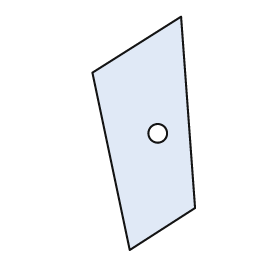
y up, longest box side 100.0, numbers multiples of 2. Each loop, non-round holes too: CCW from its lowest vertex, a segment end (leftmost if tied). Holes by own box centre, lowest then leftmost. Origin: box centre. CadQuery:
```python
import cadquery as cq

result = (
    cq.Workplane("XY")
    .moveTo(-6.0, -50.0)
    .lineTo(22.0, -32.0)
    .lineTo(16.0, 50.0)
    .lineTo(-22.0, 26.0)
    .close()
    .moveTo(6.0, 0.0)
    .circle(4.0)
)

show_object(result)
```